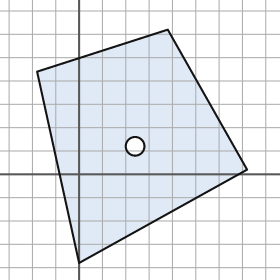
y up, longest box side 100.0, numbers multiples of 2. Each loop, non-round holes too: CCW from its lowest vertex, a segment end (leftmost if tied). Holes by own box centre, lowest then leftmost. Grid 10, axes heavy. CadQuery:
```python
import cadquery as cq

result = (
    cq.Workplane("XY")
    .moveTo(0.0, -38.0)
    .lineTo(72.0, 2.0)
    .lineTo(38.0, 62.0)
    .lineTo(-18.0, 44.0)
    .close()
    .moveTo(24.0, 12.0)
    .circle(4.0)
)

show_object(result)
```